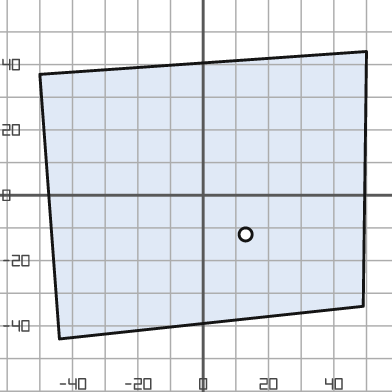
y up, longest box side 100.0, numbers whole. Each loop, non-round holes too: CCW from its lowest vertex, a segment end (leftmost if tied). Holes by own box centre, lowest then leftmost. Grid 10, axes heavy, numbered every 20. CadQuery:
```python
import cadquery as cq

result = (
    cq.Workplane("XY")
    .moveTo(-44.0, -44.0)
    .lineTo(49.0, -34.0)
    .lineTo(50.0, 44.0)
    .lineTo(-50.0, 37.0)
    .close()
    .moveTo(13.0, -12.0)
    .circle(2.0)
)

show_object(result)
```